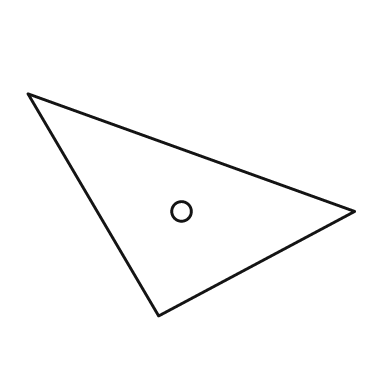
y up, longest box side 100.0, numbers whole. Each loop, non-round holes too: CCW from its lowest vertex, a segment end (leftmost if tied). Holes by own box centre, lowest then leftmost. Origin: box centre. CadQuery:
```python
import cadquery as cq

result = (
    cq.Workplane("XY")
    .moveTo(-10.0, -34.0)
    .lineTo(50.0, -2.0)
    .lineTo(-50.0, 34.0)
    .close()
    .moveTo(-3.0, -2.0)
    .circle(3.0)
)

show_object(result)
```